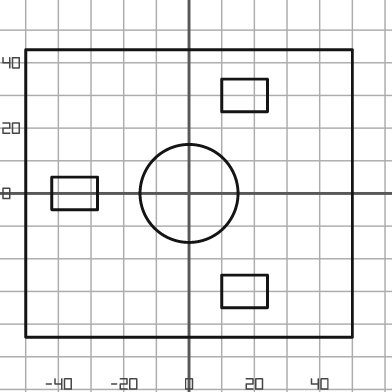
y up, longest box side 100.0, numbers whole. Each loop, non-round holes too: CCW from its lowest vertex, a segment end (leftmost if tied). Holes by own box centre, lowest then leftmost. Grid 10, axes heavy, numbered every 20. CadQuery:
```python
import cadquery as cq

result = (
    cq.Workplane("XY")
    .moveTo(-50.0, -44.0)
    .lineTo(50.0, -44.0)
    .lineTo(50.0, 44.0)
    .lineTo(-50.0, 44.0)
    .close()
    .moveTo(10.0, -35.0)
    .lineTo(24.0, -35.0)
    .lineTo(24.0, -25.0)
    .lineTo(10.0, -25.0)
    .close()
    .moveTo(-42.0, -5.0)
    .lineTo(-28.0, -5.0)
    .lineTo(-28.0, 5.0)
    .lineTo(-42.0, 5.0)
    .close()
    .moveTo(0.0, 0.0)
    .circle(15.0)
    .moveTo(10.0, 25.0)
    .lineTo(24.0, 25.0)
    .lineTo(24.0, 35.0)
    .lineTo(10.0, 35.0)
    .close()
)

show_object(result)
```